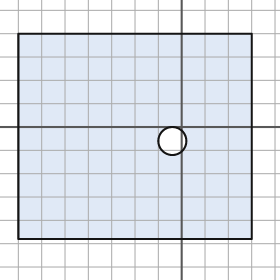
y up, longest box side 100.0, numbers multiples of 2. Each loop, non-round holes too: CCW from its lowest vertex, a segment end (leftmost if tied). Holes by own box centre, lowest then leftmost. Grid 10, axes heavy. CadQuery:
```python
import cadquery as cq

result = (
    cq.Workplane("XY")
    .moveTo(-70.0, -48.0)
    .lineTo(30.0, -48.0)
    .lineTo(30.0, 40.0)
    .lineTo(-70.0, 40.0)
    .close()
    .moveTo(-4.0, -6.0)
    .circle(6.0)
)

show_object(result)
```